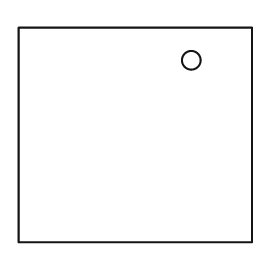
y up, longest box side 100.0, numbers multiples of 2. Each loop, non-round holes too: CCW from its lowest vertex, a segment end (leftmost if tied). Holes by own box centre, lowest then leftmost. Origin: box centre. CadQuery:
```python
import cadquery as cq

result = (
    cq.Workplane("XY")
    .moveTo(-50.0, -46.0)
    .lineTo(50.0, -46.0)
    .lineTo(50.0, 46.0)
    .lineTo(-50.0, 46.0)
    .close()
    .moveTo(24.0, 32.0)
    .circle(4.0)
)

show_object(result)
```